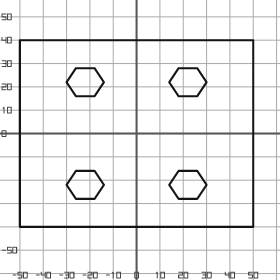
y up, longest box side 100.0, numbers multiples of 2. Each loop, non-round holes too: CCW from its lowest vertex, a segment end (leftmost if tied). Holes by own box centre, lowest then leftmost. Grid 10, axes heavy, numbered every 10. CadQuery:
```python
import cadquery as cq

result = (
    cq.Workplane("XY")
    .moveTo(-50.0, -40.0)
    .lineTo(50.0, -40.0)
    .lineTo(50.0, 40.0)
    .lineTo(-50.0, 40.0)
    .close()
    .moveTo(-26.0, -28.0)
    .lineTo(-18.0, -28.0)
    .lineTo(-14.0, -22.0)
    .lineTo(-18.0, -16.0)
    .lineTo(-26.0, -16.0)
    .lineTo(-30.0, -22.0)
    .close()
    .moveTo(18.0, -28.0)
    .lineTo(26.0, -28.0)
    .lineTo(30.0, -22.0)
    .lineTo(26.0, -16.0)
    .lineTo(18.0, -16.0)
    .lineTo(14.0, -22.0)
    .close()
    .moveTo(-26.0, 16.0)
    .lineTo(-18.0, 16.0)
    .lineTo(-14.0, 22.0)
    .lineTo(-18.0, 28.0)
    .lineTo(-26.0, 28.0)
    .lineTo(-30.0, 22.0)
    .close()
    .moveTo(18.0, 16.0)
    .lineTo(26.0, 16.0)
    .lineTo(30.0, 22.0)
    .lineTo(26.0, 28.0)
    .lineTo(18.0, 28.0)
    .lineTo(14.0, 22.0)
    .close()
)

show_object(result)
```